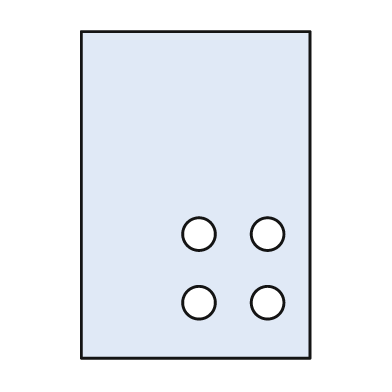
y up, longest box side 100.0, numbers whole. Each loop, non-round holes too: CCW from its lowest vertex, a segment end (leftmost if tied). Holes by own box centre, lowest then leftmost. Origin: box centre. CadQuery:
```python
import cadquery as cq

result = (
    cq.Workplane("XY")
    .moveTo(-35.0, -50.0)
    .lineTo(35.0, -50.0)
    .lineTo(35.0, 50.0)
    .lineTo(-35.0, 50.0)
    .close()
    .moveTo(1.0, -33.0)
    .circle(5.0)
    .moveTo(22.0, -33.0)
    .circle(5.0)
    .moveTo(1.0, -12.0)
    .circle(5.0)
    .moveTo(22.0, -12.0)
    .circle(5.0)
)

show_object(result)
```